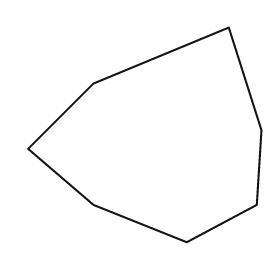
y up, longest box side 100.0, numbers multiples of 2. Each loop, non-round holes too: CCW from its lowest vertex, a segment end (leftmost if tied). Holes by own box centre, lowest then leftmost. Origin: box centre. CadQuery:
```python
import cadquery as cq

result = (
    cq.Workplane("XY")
    .moveTo(18.0, -46.0)
    .lineTo(48.0, -30.0)
    .lineTo(50.0, 2.0)
    .lineTo(36.0, 46.0)
    .lineTo(-22.0, 22.0)
    .lineTo(-50.0, -6.0)
    .lineTo(-22.0, -30.0)
    .close()
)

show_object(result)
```